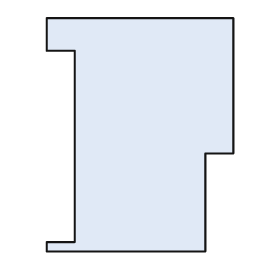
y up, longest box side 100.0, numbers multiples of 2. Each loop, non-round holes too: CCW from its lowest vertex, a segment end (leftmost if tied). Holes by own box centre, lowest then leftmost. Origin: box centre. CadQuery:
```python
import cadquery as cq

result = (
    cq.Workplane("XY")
    .moveTo(-40.0, -50.0)
    .lineTo(28.0, -50.0)
    .lineTo(28.0, -8.0)
    .lineTo(40.0, -8.0)
    .lineTo(40.0, 50.0)
    .lineTo(-40.0, 50.0)
    .lineTo(-40.0, 36.0)
    .lineTo(-28.0, 36.0)
    .lineTo(-28.0, -46.0)
    .lineTo(-40.0, -46.0)
    .close()
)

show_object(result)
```